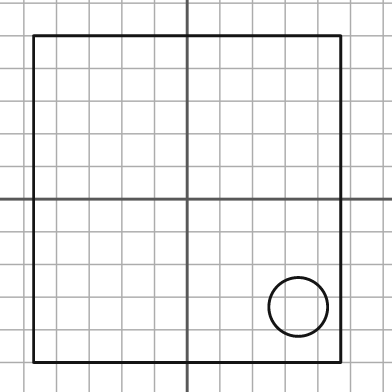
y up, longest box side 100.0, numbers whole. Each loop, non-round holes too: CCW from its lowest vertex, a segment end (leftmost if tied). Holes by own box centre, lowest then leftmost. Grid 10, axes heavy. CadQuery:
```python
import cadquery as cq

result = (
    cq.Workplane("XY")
    .moveTo(-47.0, -50.0)
    .lineTo(47.0, -50.0)
    .lineTo(47.0, 50.0)
    .lineTo(-47.0, 50.0)
    .close()
    .moveTo(34.0, -33.0)
    .circle(9.0)
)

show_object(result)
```